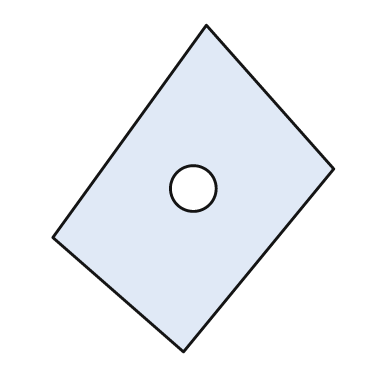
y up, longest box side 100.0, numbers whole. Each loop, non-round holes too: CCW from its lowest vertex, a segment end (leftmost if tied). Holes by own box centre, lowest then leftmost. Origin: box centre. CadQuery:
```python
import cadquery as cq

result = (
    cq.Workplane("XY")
    .moveTo(-3.0, -50.0)
    .lineTo(43.0, 6.0)
    .lineTo(4.0, 50.0)
    .lineTo(-43.0, -15.0)
    .close()
    .moveTo(0.0, 0.0)
    .circle(7.0)
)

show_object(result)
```